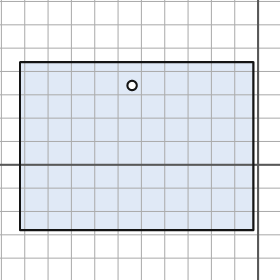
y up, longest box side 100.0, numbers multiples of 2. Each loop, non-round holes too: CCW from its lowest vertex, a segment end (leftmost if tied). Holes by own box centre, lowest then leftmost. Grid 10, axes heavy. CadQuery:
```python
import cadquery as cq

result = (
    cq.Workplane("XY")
    .moveTo(-102.0, -28.0)
    .lineTo(-2.0, -28.0)
    .lineTo(-2.0, 44.0)
    .lineTo(-102.0, 44.0)
    .close()
    .moveTo(-54.0, 34.0)
    .circle(2.0)
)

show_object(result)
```